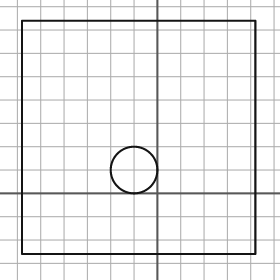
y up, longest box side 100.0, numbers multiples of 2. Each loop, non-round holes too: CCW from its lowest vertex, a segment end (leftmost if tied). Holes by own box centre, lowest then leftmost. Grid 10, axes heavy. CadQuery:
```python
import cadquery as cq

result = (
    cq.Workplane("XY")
    .moveTo(-58.0, -26.0)
    .lineTo(42.0, -26.0)
    .lineTo(42.0, 74.0)
    .lineTo(-58.0, 74.0)
    .close()
    .moveTo(-10.0, 10.0)
    .circle(10.0)
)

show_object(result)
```